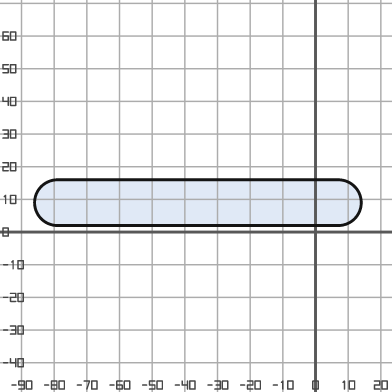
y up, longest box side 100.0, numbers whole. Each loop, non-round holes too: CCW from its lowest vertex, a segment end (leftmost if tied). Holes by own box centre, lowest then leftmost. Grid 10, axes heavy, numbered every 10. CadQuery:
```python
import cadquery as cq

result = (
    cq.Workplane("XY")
    .moveTo(-79.0, 2.0)
    .lineTo(7.0, 2.0)
    .threePointArc((14.0, 9.0), (7.0, 16.0))
    .lineTo(-79.0, 16.0)
    .threePointArc((-86.0, 9.0), (-79.0, 2.0))
    .close()
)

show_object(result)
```